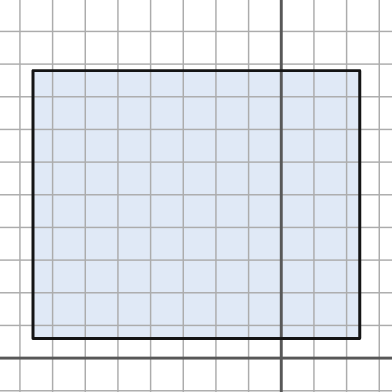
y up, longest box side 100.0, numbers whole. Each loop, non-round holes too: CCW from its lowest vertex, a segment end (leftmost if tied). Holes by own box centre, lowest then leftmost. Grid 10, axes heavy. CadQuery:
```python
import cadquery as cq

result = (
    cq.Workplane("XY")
    .moveTo(-76.0, 6.0)
    .lineTo(24.0, 6.0)
    .lineTo(24.0, 88.0)
    .lineTo(-76.0, 88.0)
    .close()
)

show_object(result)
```